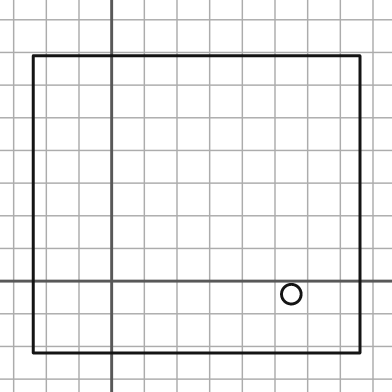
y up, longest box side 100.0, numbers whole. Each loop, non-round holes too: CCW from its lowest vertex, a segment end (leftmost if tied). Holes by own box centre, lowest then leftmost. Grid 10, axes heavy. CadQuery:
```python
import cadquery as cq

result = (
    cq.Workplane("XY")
    .moveTo(-24.0, -22.0)
    .lineTo(76.0, -22.0)
    .lineTo(76.0, 69.0)
    .lineTo(-24.0, 69.0)
    .close()
    .moveTo(55.0, -4.0)
    .circle(3.0)
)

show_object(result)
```